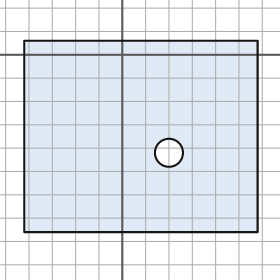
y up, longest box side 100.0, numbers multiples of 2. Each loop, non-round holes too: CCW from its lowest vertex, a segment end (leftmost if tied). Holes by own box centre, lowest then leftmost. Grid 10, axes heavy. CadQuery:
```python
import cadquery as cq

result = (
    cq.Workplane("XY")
    .moveTo(-42.0, -76.0)
    .lineTo(58.0, -76.0)
    .lineTo(58.0, 6.0)
    .lineTo(-42.0, 6.0)
    .close()
    .moveTo(20.0, -42.0)
    .circle(6.0)
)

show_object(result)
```